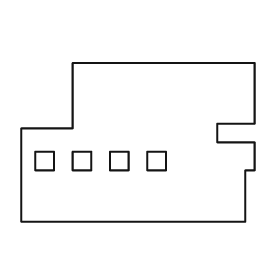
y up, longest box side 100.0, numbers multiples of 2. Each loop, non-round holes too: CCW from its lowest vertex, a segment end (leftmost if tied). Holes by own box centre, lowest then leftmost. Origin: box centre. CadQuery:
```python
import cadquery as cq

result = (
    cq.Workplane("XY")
    .moveTo(-50.0, -34.0)
    .lineTo(46.0, -34.0)
    .lineTo(46.0, -12.0)
    .lineTo(50.0, -12.0)
    .lineTo(50.0, 0.0)
    .lineTo(34.0, 0.0)
    .lineTo(34.0, 8.0)
    .lineTo(50.0, 8.0)
    .lineTo(50.0, 34.0)
    .lineTo(-28.0, 34.0)
    .lineTo(-28.0, 6.0)
    .lineTo(-50.0, 6.0)
    .close()
    .moveTo(-44.0, -12.0)
    .lineTo(-36.0, -12.0)
    .lineTo(-36.0, -4.0)
    .lineTo(-44.0, -4.0)
    .close()
    .moveTo(-28.0, -12.0)
    .lineTo(-20.0, -12.0)
    .lineTo(-20.0, -4.0)
    .lineTo(-28.0, -4.0)
    .close()
    .moveTo(-12.0, -12.0)
    .lineTo(-4.0, -12.0)
    .lineTo(-4.0, -4.0)
    .lineTo(-12.0, -4.0)
    .close()
    .moveTo(4.0, -12.0)
    .lineTo(12.0, -12.0)
    .lineTo(12.0, -4.0)
    .lineTo(4.0, -4.0)
    .close()
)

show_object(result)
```